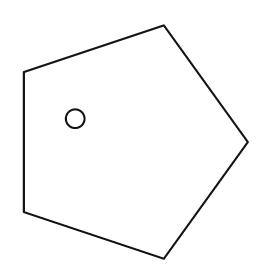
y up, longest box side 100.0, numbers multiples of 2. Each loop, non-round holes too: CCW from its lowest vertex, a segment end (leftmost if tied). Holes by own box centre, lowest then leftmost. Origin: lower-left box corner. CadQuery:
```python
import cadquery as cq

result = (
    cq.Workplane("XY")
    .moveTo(60.0, 0.0)
    .lineTo(96.0, 50.0)
    .lineTo(60.0, 100.0)
    .lineTo(0.0, 80.0)
    .lineTo(0.0, 20.0)
    .close()
    .moveTo(22.0, 60.0)
    .circle(4.0)
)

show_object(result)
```